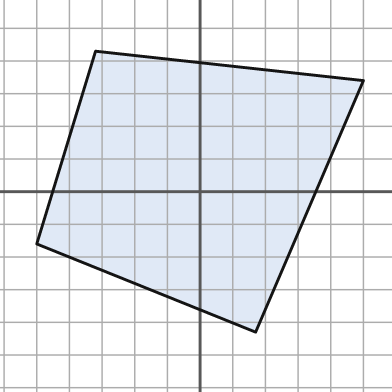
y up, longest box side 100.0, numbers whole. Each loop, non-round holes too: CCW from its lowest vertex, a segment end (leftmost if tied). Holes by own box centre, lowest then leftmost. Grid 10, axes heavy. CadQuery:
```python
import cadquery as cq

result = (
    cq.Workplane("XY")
    .moveTo(17.0, -43.0)
    .lineTo(50.0, 34.0)
    .lineTo(-32.0, 43.0)
    .lineTo(-50.0, -16.0)
    .close()
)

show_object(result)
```